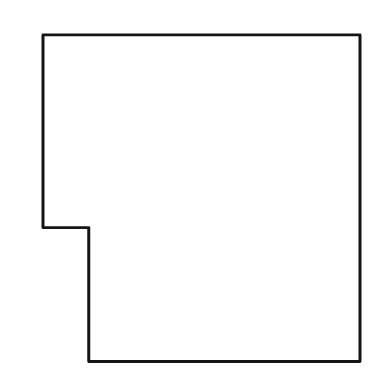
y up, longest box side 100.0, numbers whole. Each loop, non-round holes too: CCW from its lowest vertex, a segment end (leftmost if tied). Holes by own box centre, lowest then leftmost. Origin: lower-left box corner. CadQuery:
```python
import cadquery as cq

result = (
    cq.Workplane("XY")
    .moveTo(14.0, 0.0)
    .lineTo(97.0, 0.0)
    .lineTo(97.0, 100.0)
    .lineTo(0.0, 100.0)
    .lineTo(0.0, 41.0)
    .lineTo(14.0, 41.0)
    .close()
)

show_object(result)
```